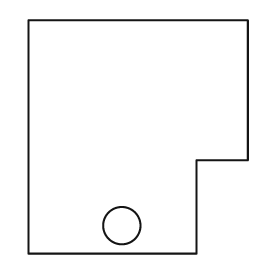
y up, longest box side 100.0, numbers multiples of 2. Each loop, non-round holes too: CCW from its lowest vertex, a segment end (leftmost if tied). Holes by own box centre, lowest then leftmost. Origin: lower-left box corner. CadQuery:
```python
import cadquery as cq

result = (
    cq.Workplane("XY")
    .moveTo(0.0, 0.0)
    .lineTo(72.0, 0.0)
    .lineTo(72.0, 40.0)
    .lineTo(94.0, 40.0)
    .lineTo(94.0, 100.0)
    .lineTo(0.0, 100.0)
    .close()
    .moveTo(40.0, 12.0)
    .circle(8.0)
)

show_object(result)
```